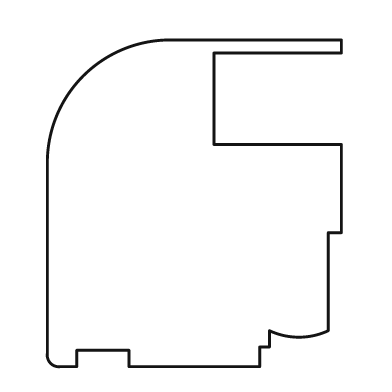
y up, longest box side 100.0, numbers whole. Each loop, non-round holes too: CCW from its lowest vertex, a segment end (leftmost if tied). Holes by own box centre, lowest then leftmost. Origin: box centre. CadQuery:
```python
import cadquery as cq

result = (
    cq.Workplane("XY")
    .moveTo(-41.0, -50.0)
    .lineTo(-36.0, -50.0)
    .lineTo(-36.0, -45.0)
    .lineTo(-20.0, -45.0)
    .lineTo(-20.0, -50.0)
    .lineTo(20.0, -50.0)
    .lineTo(20.0, -44.0)
    .lineTo(23.0, -44.0)
    .lineTo(23.0, -39.0)
    .threePointArc((32.0, -41.0), (41.0, -39.0))
    .lineTo(41.0, -9.0)
    .lineTo(45.0, -9.0)
    .lineTo(45.0, 18.0)
    .lineTo(6.0, 18.0)
    .lineTo(6.0, 46.0)
    .lineTo(45.0, 46.0)
    .lineTo(45.0, 50.0)
    .lineTo(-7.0, 50.0)
    .threePointArc((-34.0, 39.0), (-45.0, 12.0))
    .lineTo(-45.0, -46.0)
    .threePointArc((-44.0, -49.0), (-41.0, -50.0))
    .close()
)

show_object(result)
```